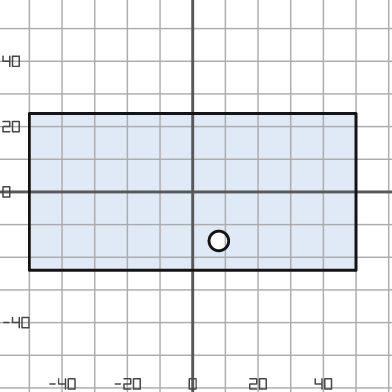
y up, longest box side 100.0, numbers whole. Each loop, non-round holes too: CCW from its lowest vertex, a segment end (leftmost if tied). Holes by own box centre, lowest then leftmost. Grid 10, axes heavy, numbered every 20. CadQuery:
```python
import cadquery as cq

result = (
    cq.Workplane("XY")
    .moveTo(-50.0, -24.0)
    .lineTo(50.0, -24.0)
    .lineTo(50.0, 24.0)
    .lineTo(-50.0, 24.0)
    .close()
    .moveTo(8.0, -15.0)
    .circle(3.0)
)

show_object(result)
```